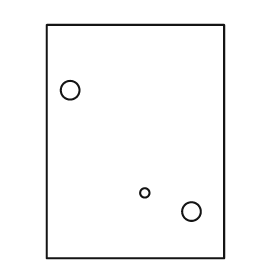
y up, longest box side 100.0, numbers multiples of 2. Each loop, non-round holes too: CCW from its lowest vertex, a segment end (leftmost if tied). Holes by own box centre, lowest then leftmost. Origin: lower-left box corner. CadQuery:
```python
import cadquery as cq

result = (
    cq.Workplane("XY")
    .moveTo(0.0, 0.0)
    .lineTo(76.0, 0.0)
    .lineTo(76.0, 100.0)
    .lineTo(0.0, 100.0)
    .close()
    .moveTo(62.0, 20.0)
    .circle(4.0)
    .moveTo(42.0, 28.0)
    .circle(2.0)
    .moveTo(10.0, 72.0)
    .circle(4.0)
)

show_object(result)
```